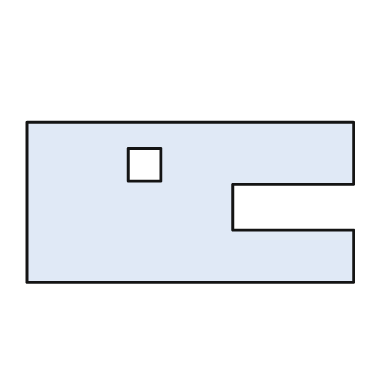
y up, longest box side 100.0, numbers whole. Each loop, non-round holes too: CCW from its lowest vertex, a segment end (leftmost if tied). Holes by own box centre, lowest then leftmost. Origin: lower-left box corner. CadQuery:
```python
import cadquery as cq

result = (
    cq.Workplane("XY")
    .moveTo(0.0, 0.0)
    .lineTo(100.0, 0.0)
    .lineTo(100.0, 16.0)
    .lineTo(63.0, 16.0)
    .lineTo(63.0, 30.0)
    .lineTo(100.0, 30.0)
    .lineTo(100.0, 49.0)
    .lineTo(0.0, 49.0)
    .close()
    .moveTo(31.0, 31.0)
    .lineTo(41.0, 31.0)
    .lineTo(41.0, 41.0)
    .lineTo(31.0, 41.0)
    .close()
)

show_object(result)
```